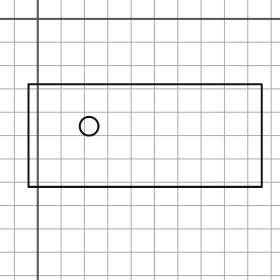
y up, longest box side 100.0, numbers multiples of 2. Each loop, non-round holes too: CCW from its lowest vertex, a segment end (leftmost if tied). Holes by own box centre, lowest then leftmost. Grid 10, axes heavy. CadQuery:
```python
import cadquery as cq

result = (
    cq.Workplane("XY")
    .moveTo(-4.0, -72.0)
    .lineTo(96.0, -72.0)
    .lineTo(96.0, -28.0)
    .lineTo(-4.0, -28.0)
    .close()
    .moveTo(22.0, -46.0)
    .circle(4.0)
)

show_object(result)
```